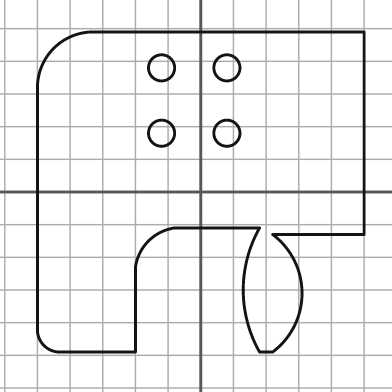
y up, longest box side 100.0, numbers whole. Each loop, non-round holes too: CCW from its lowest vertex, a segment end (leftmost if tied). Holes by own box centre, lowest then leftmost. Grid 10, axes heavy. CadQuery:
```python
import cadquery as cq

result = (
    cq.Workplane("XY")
    .moveTo(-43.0, -49.0)
    .lineTo(-20.0, -49.0)
    .lineTo(-20.0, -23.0)
    .threePointArc((-16.0, -15.0), (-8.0, -11.0))
    .lineTo(18.0, -11.0)
    .threePointArc((13.0, -30.0), (18.0, -49.0))
    .lineTo(22.0, -49.0)
    .threePointArc((31.0, -31.0), (22.0, -13.0))
    .lineTo(50.0, -13.0)
    .lineTo(50.0, 49.0)
    .lineTo(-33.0, 49.0)
    .threePointArc((-45.0, 44.0), (-50.0, 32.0))
    .lineTo(-50.0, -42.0)
    .threePointArc((-48.0, -47.0), (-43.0, -49.0))
    .close()
    .moveTo(-12.0, 18.0)
    .circle(4.0)
    .moveTo(8.0, 18.0)
    .circle(4.0)
    .moveTo(-12.0, 38.0)
    .circle(4.0)
    .moveTo(8.0, 38.0)
    .circle(4.0)
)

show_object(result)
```